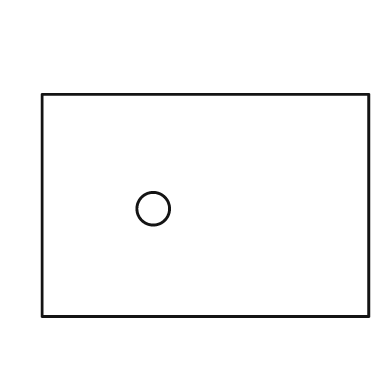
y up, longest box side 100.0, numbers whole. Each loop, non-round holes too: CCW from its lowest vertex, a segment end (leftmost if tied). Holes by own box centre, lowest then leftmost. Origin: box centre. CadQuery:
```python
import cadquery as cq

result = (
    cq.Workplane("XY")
    .moveTo(-50.0, -34.0)
    .lineTo(50.0, -34.0)
    .lineTo(50.0, 34.0)
    .lineTo(-50.0, 34.0)
    .close()
    .moveTo(-16.0, -1.0)
    .circle(5.0)
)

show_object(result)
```